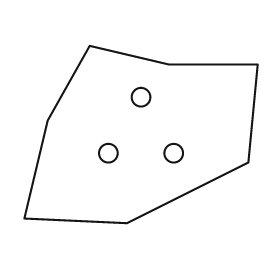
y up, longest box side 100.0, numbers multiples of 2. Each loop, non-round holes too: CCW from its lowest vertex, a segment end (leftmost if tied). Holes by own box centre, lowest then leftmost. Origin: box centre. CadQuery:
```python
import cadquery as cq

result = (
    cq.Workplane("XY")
    .moveTo(-6.0, -38.0)
    .lineTo(46.0, -12.0)
    .lineTo(50.0, 30.0)
    .lineTo(12.0, 30.0)
    .lineTo(-22.0, 38.0)
    .lineTo(-40.0, 6.0)
    .lineTo(-50.0, -36.0)
    .close()
    .moveTo(-14.0, -8.0)
    .circle(4.0)
    .moveTo(14.0, -8.0)
    .circle(4.0)
    .moveTo(0.0, 16.0)
    .circle(4.0)
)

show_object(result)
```